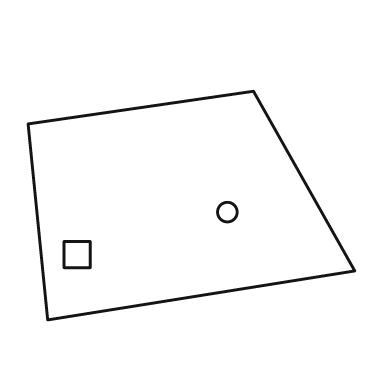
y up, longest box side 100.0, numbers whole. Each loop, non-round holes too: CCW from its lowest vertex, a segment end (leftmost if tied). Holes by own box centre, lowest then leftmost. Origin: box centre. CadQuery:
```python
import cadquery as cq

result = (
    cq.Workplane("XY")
    .moveTo(-44.0, -35.0)
    .lineTo(50.0, -20.0)
    .lineTo(19.0, 35.0)
    .lineTo(-50.0, 25.0)
    .close()
    .moveTo(-39.0, -19.0)
    .lineTo(-31.0, -19.0)
    .lineTo(-31.0, -11.0)
    .lineTo(-39.0, -11.0)
    .close()
    .moveTo(11.0, -2.0)
    .circle(3.0)
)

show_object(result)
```